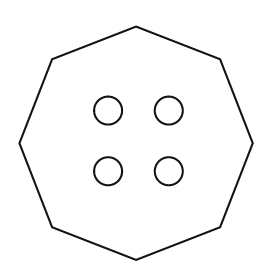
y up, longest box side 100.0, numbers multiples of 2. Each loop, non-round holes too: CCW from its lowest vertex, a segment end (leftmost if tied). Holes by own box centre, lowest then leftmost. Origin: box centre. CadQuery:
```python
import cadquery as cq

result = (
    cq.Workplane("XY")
    .moveTo(0.0, -50.0)
    .lineTo(36.0, -36.0)
    .lineTo(50.0, 0.0)
    .lineTo(36.0, 36.0)
    .lineTo(0.0, 50.0)
    .lineTo(-36.0, 36.0)
    .lineTo(-50.0, 0.0)
    .lineTo(-36.0, -36.0)
    .close()
    .moveTo(-12.0, -12.0)
    .circle(6.0)
    .moveTo(14.0, -12.0)
    .circle(6.0)
    .moveTo(-12.0, 14.0)
    .circle(6.0)
    .moveTo(14.0, 14.0)
    .circle(6.0)
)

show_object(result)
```